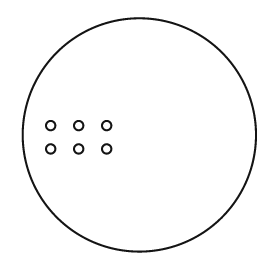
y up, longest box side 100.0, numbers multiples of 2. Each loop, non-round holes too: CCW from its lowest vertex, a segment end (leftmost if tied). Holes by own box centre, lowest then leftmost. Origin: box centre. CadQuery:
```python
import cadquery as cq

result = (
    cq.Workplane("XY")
    .moveTo(0.0, 0.0)
    .circle(50.0)
    .moveTo(-38.0, -6.0)
    .circle(2.0)
    .moveTo(-26.0, -6.0)
    .circle(2.0)
    .moveTo(-14.0, -6.0)
    .circle(2.0)
    .moveTo(-38.0, 4.0)
    .circle(2.0)
    .moveTo(-26.0, 4.0)
    .circle(2.0)
    .moveTo(-14.0, 4.0)
    .circle(2.0)
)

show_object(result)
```